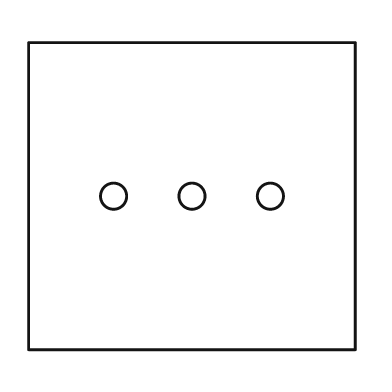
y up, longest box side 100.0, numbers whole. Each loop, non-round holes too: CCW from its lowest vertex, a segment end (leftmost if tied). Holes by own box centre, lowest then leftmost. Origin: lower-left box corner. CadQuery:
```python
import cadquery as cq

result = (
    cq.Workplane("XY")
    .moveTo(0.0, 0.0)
    .lineTo(100.0, 0.0)
    .lineTo(100.0, 94.0)
    .lineTo(0.0, 94.0)
    .close()
    .moveTo(26.0, 47.0)
    .circle(4.0)
    .moveTo(50.0, 47.0)
    .circle(4.0)
    .moveTo(74.0, 47.0)
    .circle(4.0)
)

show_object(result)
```